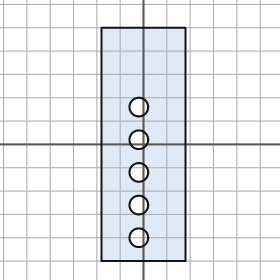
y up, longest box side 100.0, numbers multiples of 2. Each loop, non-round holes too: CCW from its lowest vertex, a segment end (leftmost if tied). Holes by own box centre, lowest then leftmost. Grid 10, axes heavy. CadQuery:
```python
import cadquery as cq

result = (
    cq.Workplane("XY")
    .moveTo(-18.0, -50.0)
    .lineTo(18.0, -50.0)
    .lineTo(18.0, 50.0)
    .lineTo(-18.0, 50.0)
    .close()
    .moveTo(-2.0, -40.0)
    .circle(4.0)
    .moveTo(-2.0, -26.0)
    .circle(4.0)
    .moveTo(-2.0, -12.0)
    .circle(4.0)
    .moveTo(-2.0, 2.0)
    .circle(4.0)
    .moveTo(-2.0, 16.0)
    .circle(4.0)
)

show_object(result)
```